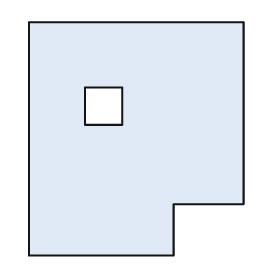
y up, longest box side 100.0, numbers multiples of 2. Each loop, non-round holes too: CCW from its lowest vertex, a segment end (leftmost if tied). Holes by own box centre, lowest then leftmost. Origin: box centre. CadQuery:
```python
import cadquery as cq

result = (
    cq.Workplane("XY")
    .moveTo(-46.0, -50.0)
    .lineTo(16.0, -50.0)
    .lineTo(16.0, -28.0)
    .lineTo(46.0, -28.0)
    .lineTo(46.0, 50.0)
    .lineTo(-46.0, 50.0)
    .close()
    .moveTo(-22.0, 6.0)
    .lineTo(-6.0, 6.0)
    .lineTo(-6.0, 22.0)
    .lineTo(-22.0, 22.0)
    .close()
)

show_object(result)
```